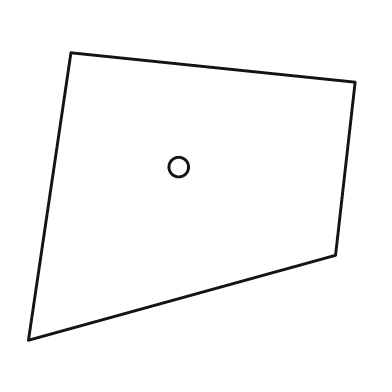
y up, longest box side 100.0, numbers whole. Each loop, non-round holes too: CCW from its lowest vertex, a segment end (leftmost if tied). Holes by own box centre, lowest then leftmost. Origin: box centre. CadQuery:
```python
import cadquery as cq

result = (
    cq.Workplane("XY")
    .moveTo(-50.0, -44.0)
    .lineTo(44.0, -18.0)
    .lineTo(50.0, 35.0)
    .lineTo(-37.0, 44.0)
    .close()
    .moveTo(-4.0, 9.0)
    .circle(3.0)
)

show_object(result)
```